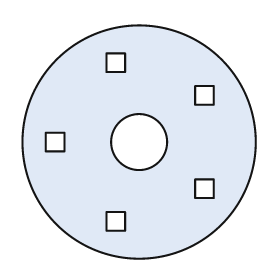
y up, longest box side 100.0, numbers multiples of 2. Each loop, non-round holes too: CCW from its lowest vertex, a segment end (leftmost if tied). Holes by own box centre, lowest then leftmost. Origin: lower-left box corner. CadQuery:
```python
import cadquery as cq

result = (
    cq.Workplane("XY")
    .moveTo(50.0, 50.0)
    .circle(50.0)
    .moveTo(36.0, 12.0)
    .lineTo(44.0, 12.0)
    .lineTo(44.0, 20.0)
    .lineTo(36.0, 20.0)
    .close()
    .moveTo(74.0, 26.0)
    .lineTo(82.0, 26.0)
    .lineTo(82.0, 34.0)
    .lineTo(74.0, 34.0)
    .close()
    .moveTo(10.0, 46.0)
    .lineTo(18.0, 46.0)
    .lineTo(18.0, 54.0)
    .lineTo(10.0, 54.0)
    .close()
    .moveTo(50.0, 50.0)
    .circle(12.0)
    .moveTo(74.0, 66.0)
    .lineTo(82.0, 66.0)
    .lineTo(82.0, 74.0)
    .lineTo(74.0, 74.0)
    .close()
    .moveTo(36.0, 80.0)
    .lineTo(44.0, 80.0)
    .lineTo(44.0, 88.0)
    .lineTo(36.0, 88.0)
    .close()
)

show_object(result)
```